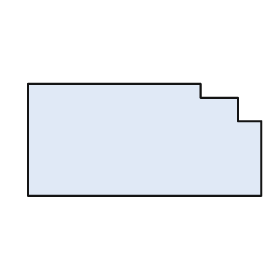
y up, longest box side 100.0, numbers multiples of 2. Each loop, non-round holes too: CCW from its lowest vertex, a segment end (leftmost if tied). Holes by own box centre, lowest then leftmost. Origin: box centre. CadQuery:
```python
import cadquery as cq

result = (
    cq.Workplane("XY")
    .moveTo(-50.0, -24.0)
    .lineTo(50.0, -24.0)
    .lineTo(50.0, 8.0)
    .lineTo(40.0, 8.0)
    .lineTo(40.0, 18.0)
    .lineTo(24.0, 18.0)
    .lineTo(24.0, 24.0)
    .lineTo(-50.0, 24.0)
    .close()
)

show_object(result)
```